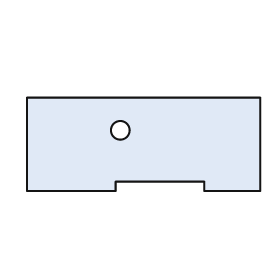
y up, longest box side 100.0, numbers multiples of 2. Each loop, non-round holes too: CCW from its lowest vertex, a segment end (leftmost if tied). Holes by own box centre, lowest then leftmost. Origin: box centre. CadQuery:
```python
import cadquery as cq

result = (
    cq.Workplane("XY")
    .moveTo(-50.0, -20.0)
    .lineTo(-12.0, -20.0)
    .lineTo(-12.0, -16.0)
    .lineTo(26.0, -16.0)
    .lineTo(26.0, -20.0)
    .lineTo(50.0, -20.0)
    .lineTo(50.0, 20.0)
    .lineTo(-50.0, 20.0)
    .close()
    .moveTo(-10.0, 6.0)
    .circle(4.0)
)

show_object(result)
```